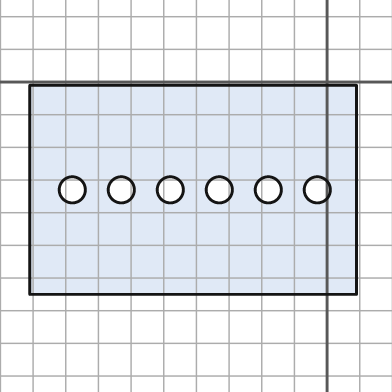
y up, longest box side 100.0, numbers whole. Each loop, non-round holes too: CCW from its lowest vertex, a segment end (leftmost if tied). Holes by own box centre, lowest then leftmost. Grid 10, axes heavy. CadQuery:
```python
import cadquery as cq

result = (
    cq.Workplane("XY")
    .moveTo(-91.0, -65.0)
    .lineTo(9.0, -65.0)
    .lineTo(9.0, -1.0)
    .lineTo(-91.0, -1.0)
    .close()
    .moveTo(-78.0, -33.0)
    .circle(4.0)
    .moveTo(-63.0, -33.0)
    .circle(4.0)
    .moveTo(-48.0, -33.0)
    .circle(4.0)
    .moveTo(-33.0, -33.0)
    .circle(4.0)
    .moveTo(-18.0, -33.0)
    .circle(4.0)
    .moveTo(-3.0, -33.0)
    .circle(4.0)
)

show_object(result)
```